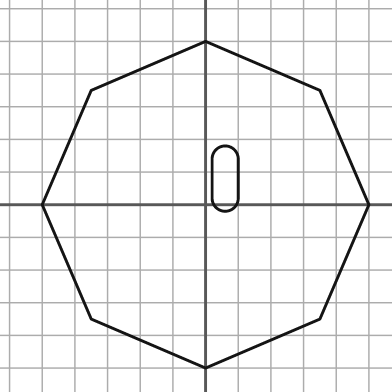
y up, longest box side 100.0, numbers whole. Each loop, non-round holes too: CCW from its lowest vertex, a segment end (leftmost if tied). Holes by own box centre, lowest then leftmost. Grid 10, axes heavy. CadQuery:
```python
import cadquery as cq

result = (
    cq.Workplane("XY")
    .moveTo(0.0, -50.0)
    .lineTo(35.0, -35.0)
    .lineTo(50.0, 0.0)
    .lineTo(35.0, 35.0)
    .lineTo(0.0, 50.0)
    .lineTo(-35.0, 35.0)
    .lineTo(-50.0, 0.0)
    .lineTo(-35.0, -35.0)
    .close()
    .moveTo(2.0, 2.0)
    .threePointArc((6.0, -2.0), (10.0, 2.0))
    .lineTo(10.0, 14.0)
    .threePointArc((6.0, 18.0), (2.0, 14.0))
    .close()
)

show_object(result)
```